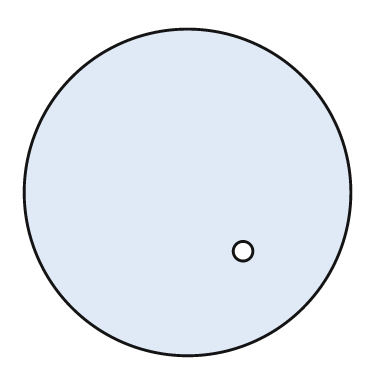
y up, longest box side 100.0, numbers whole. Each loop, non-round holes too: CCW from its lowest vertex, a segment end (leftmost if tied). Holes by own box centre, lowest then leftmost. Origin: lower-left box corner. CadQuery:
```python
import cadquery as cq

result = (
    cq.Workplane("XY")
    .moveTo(50.0, 50.0)
    .circle(50.0)
    .moveTo(67.0, 32.0)
    .circle(3.0)
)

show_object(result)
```